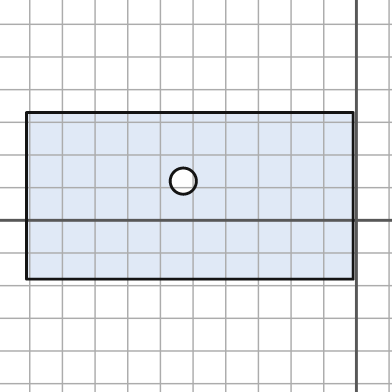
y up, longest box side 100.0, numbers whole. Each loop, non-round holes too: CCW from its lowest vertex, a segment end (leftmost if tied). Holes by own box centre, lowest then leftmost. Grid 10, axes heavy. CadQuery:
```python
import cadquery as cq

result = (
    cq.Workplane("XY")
    .moveTo(-101.0, -18.0)
    .lineTo(-1.0, -18.0)
    .lineTo(-1.0, 33.0)
    .lineTo(-101.0, 33.0)
    .close()
    .moveTo(-53.0, 12.0)
    .circle(4.0)
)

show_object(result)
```